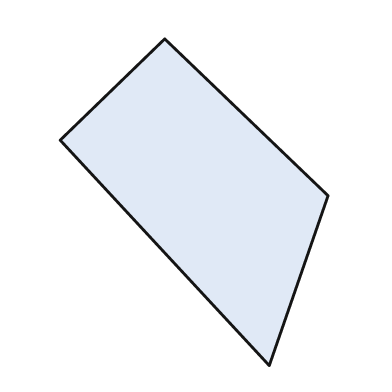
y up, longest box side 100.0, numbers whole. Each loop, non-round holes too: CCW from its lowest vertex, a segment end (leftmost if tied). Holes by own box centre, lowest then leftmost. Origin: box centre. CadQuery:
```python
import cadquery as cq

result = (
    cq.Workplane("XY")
    .moveTo(23.0, -50.0)
    .lineTo(41.0, 2.0)
    .lineTo(-9.0, 50.0)
    .lineTo(-41.0, 19.0)
    .close()
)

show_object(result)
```